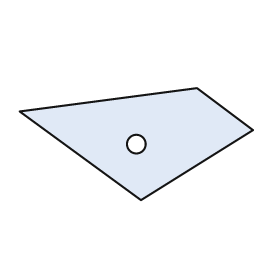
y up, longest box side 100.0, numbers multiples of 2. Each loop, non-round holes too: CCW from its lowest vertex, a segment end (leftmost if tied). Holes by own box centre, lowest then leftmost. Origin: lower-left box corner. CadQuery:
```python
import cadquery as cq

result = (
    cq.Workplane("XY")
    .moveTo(52.0, 0.0)
    .lineTo(100.0, 30.0)
    .lineTo(76.0, 48.0)
    .lineTo(0.0, 38.0)
    .close()
    .moveTo(50.0, 24.0)
    .circle(4.0)
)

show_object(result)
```